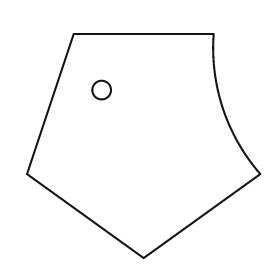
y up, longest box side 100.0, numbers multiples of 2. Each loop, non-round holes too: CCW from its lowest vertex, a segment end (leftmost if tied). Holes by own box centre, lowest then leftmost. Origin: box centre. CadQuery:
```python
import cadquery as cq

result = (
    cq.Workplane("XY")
    .moveTo(0.0, -48.0)
    .lineTo(50.0, -12.0)
    .threePointArc((34.0, 16.0), (30.0, 48.0))
    .lineTo(-30.0, 48.0)
    .lineTo(-50.0, -12.0)
    .close()
    .moveTo(-18.0, 24.0)
    .circle(4.0)
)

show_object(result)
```